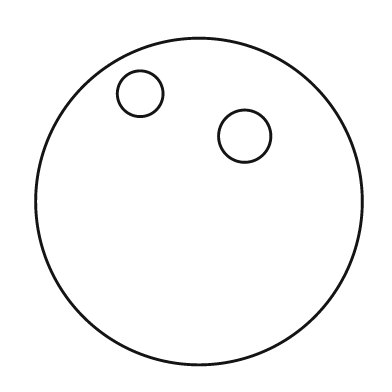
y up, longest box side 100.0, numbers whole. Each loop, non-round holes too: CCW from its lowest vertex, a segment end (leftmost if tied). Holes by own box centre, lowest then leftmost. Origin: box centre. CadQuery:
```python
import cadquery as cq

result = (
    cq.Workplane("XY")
    .moveTo(0.0, 0.0)
    .circle(50.0)
    .moveTo(14.0, 20.0)
    .circle(8.0)
    .moveTo(-18.0, 33.0)
    .circle(7.0)
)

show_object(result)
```